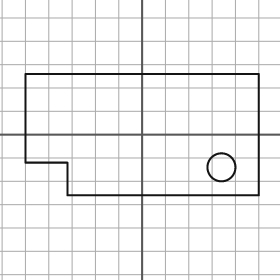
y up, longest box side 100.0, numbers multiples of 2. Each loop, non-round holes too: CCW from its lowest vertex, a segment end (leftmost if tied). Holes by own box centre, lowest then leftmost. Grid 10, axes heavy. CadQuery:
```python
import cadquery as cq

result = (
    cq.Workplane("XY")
    .moveTo(-32.0, -26.0)
    .lineTo(50.0, -26.0)
    .lineTo(50.0, 26.0)
    .lineTo(-50.0, 26.0)
    .lineTo(-50.0, -12.0)
    .lineTo(-32.0, -12.0)
    .close()
    .moveTo(34.0, -14.0)
    .circle(6.0)
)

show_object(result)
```